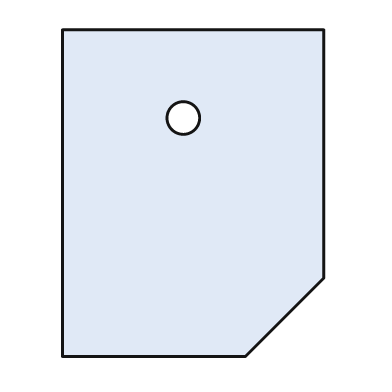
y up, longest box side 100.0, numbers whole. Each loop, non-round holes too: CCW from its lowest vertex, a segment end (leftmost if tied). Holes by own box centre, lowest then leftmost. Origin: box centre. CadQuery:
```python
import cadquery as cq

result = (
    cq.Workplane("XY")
    .moveTo(-40.0, -50.0)
    .lineTo(16.0, -50.0)
    .lineTo(40.0, -26.0)
    .lineTo(40.0, 50.0)
    .lineTo(-40.0, 50.0)
    .close()
    .moveTo(-3.0, 23.0)
    .circle(5.0)
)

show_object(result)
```